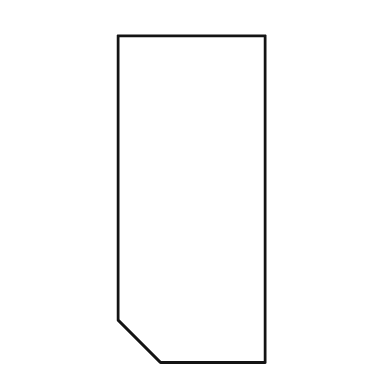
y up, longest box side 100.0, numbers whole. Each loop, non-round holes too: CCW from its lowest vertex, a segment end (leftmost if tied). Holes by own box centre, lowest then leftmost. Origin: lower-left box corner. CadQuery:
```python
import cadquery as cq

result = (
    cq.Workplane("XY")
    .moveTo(13.0, 0.0)
    .lineTo(45.0, 0.0)
    .lineTo(45.0, 100.0)
    .lineTo(0.0, 100.0)
    .lineTo(0.0, 13.0)
    .close()
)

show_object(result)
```